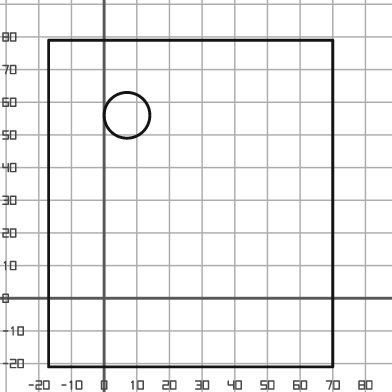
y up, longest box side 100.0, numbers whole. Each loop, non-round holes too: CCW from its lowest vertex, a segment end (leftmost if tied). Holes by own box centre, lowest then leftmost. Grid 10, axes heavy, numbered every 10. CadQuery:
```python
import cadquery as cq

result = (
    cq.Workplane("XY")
    .moveTo(-17.0, -21.0)
    .lineTo(70.0, -21.0)
    .lineTo(70.0, 79.0)
    .lineTo(-17.0, 79.0)
    .close()
    .moveTo(7.0, 56.0)
    .circle(7.0)
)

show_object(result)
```